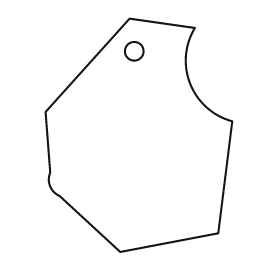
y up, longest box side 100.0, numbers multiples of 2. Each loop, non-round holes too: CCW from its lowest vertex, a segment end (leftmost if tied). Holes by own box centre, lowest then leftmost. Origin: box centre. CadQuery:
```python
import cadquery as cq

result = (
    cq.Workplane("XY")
    .moveTo(-8.0, -50.0)
    .lineTo(34.0, -42.0)
    .lineTo(40.0, 6.0)
    .threePointArc((22.0, 22.0), (24.0, 46.0))
    .lineTo(-4.0, 50.0)
    .lineTo(-40.0, 10.0)
    .lineTo(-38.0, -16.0)
    .threePointArc((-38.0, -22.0), (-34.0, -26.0))
    .close()
    .moveTo(-2.0, 36.0)
    .circle(4.0)
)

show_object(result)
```